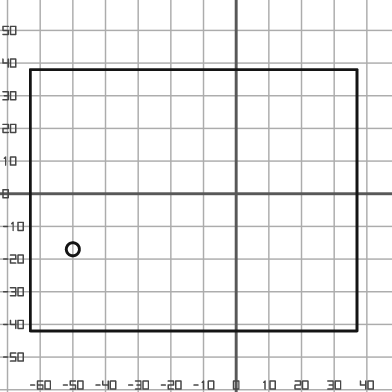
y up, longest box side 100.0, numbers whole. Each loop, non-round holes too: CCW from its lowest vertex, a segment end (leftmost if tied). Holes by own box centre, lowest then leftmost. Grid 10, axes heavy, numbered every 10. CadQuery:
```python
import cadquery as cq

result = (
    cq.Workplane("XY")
    .moveTo(-63.0, -42.0)
    .lineTo(37.0, -42.0)
    .lineTo(37.0, 38.0)
    .lineTo(-63.0, 38.0)
    .close()
    .moveTo(-50.0, -17.0)
    .circle(2.0)
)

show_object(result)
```